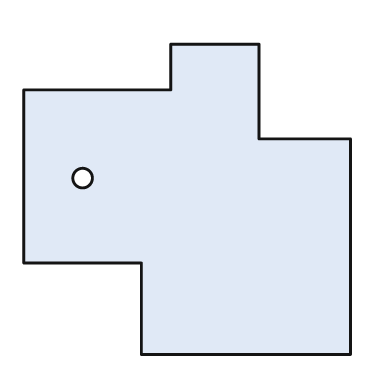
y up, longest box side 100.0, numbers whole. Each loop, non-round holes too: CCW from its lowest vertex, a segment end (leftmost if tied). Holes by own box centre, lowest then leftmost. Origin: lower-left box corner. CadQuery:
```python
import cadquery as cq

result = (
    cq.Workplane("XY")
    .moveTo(36.0, 0.0)
    .lineTo(100.0, 0.0)
    .lineTo(100.0, 66.0)
    .lineTo(72.0, 66.0)
    .lineTo(72.0, 95.0)
    .lineTo(45.0, 95.0)
    .lineTo(45.0, 81.0)
    .lineTo(0.0, 81.0)
    .lineTo(0.0, 28.0)
    .lineTo(36.0, 28.0)
    .close()
    .moveTo(18.0, 54.0)
    .circle(3.0)
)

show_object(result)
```